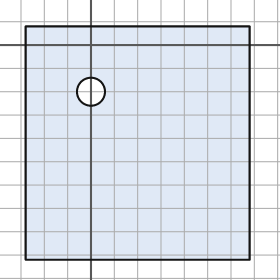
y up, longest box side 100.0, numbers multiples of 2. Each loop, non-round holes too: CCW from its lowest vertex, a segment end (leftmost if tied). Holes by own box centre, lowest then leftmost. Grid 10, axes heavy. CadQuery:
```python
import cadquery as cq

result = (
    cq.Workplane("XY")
    .moveTo(-28.0, -92.0)
    .lineTo(68.0, -92.0)
    .lineTo(68.0, 8.0)
    .lineTo(-28.0, 8.0)
    .close()
    .moveTo(0.0, -20.0)
    .circle(6.0)
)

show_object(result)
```